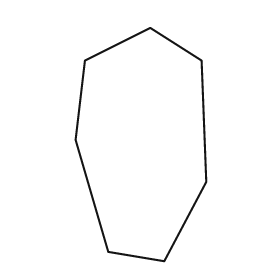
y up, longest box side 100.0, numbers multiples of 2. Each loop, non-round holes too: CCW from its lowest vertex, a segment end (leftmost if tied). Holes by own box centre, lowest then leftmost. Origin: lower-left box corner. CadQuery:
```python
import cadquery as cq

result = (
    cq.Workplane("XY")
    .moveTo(38.0, 0.0)
    .lineTo(56.0, 34.0)
    .lineTo(54.0, 86.0)
    .lineTo(32.0, 100.0)
    .lineTo(4.0, 86.0)
    .lineTo(0.0, 52.0)
    .lineTo(14.0, 4.0)
    .close()
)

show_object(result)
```